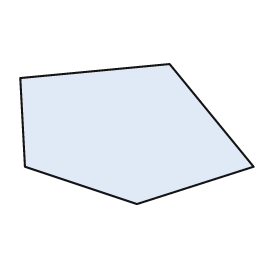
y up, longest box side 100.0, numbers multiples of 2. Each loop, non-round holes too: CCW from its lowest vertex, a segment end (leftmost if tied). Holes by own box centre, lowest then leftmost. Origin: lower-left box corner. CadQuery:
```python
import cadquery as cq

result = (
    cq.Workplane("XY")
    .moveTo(50.0, 0.0)
    .lineTo(100.0, 16.0)
    .lineTo(64.0, 60.0)
    .lineTo(0.0, 54.0)
    .lineTo(2.0, 16.0)
    .close()
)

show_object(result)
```